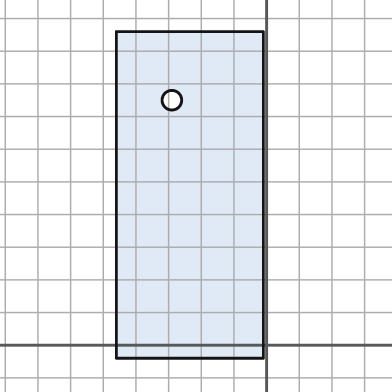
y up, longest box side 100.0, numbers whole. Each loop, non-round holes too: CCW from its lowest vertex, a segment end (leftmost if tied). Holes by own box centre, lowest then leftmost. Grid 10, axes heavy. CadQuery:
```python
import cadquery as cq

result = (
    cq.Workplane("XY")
    .moveTo(-46.0, -4.0)
    .lineTo(-1.0, -4.0)
    .lineTo(-1.0, 96.0)
    .lineTo(-46.0, 96.0)
    .close()
    .moveTo(-29.0, 75.0)
    .circle(3.0)
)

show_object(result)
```